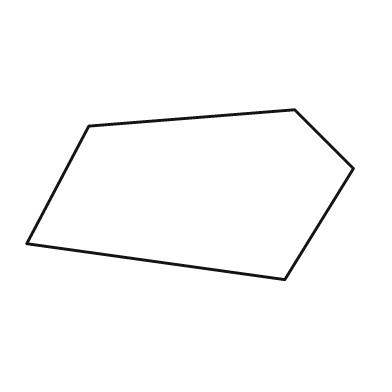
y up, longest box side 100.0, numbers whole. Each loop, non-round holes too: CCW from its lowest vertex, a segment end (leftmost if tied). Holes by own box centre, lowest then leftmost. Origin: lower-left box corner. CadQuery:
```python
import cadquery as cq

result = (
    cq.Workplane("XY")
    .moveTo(79.0, 0.0)
    .lineTo(100.0, 34.0)
    .lineTo(82.0, 52.0)
    .lineTo(19.0, 47.0)
    .lineTo(0.0, 11.0)
    .close()
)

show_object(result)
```